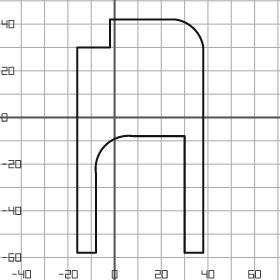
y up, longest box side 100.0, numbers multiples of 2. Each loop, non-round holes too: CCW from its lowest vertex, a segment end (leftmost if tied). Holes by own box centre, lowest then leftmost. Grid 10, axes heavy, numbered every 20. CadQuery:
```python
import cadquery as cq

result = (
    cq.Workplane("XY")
    .moveTo(-16.0, -58.0)
    .lineTo(-8.0, -58.0)
    .lineTo(-8.0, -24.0)
    .threePointArc((-4.0, -12.0), (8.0, -8.0))
    .lineTo(30.0, -8.0)
    .lineTo(30.0, -58.0)
    .lineTo(38.0, -58.0)
    .lineTo(38.0, 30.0)
    .threePointArc((34.0, 38.0), (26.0, 42.0))
    .lineTo(-2.0, 42.0)
    .lineTo(-2.0, 30.0)
    .lineTo(-16.0, 30.0)
    .close()
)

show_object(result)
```